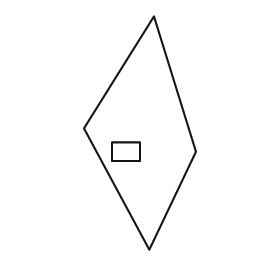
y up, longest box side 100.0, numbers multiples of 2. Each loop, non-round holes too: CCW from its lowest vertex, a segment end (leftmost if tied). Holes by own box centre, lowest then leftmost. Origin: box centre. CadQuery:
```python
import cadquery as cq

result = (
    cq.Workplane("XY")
    .moveTo(4.0, -50.0)
    .lineTo(24.0, -8.0)
    .lineTo(6.0, 50.0)
    .lineTo(-24.0, 2.0)
    .close()
    .moveTo(-12.0, -12.0)
    .lineTo(0.0, -12.0)
    .lineTo(0.0, -4.0)
    .lineTo(-12.0, -4.0)
    .close()
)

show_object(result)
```